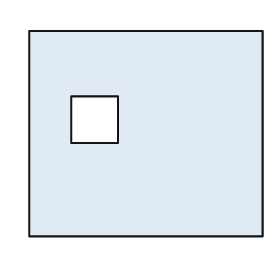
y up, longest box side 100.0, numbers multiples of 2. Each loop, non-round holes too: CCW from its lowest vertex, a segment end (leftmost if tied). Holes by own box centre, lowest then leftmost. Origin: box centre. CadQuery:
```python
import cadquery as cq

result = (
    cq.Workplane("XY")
    .moveTo(-50.0, -44.0)
    .lineTo(50.0, -44.0)
    .lineTo(50.0, 44.0)
    .lineTo(-50.0, 44.0)
    .close()
    .moveTo(-32.0, -4.0)
    .lineTo(-12.0, -4.0)
    .lineTo(-12.0, 16.0)
    .lineTo(-32.0, 16.0)
    .close()
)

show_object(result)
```